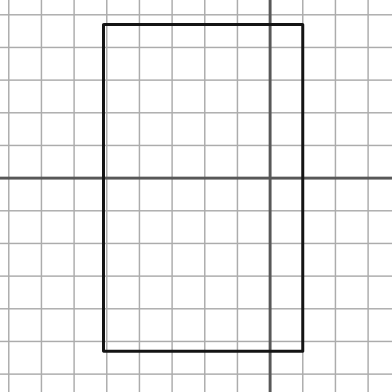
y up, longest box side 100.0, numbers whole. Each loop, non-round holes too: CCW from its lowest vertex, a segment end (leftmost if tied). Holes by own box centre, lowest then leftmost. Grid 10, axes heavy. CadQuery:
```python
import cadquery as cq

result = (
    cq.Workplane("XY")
    .moveTo(-51.0, -53.0)
    .lineTo(10.0, -53.0)
    .lineTo(10.0, 47.0)
    .lineTo(-51.0, 47.0)
    .close()
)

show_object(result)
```